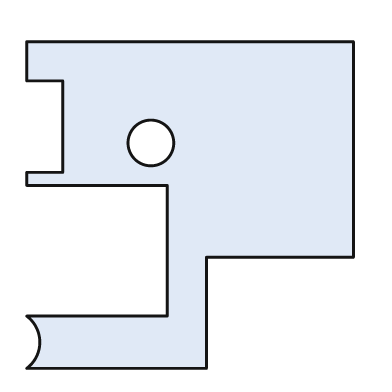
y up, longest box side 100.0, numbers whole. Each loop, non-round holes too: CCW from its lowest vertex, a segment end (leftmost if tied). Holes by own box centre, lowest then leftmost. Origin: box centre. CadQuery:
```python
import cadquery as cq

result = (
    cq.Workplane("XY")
    .moveTo(-50.0, -50.0)
    .lineTo(5.0, -50.0)
    .lineTo(5.0, -16.0)
    .lineTo(50.0, -16.0)
    .lineTo(50.0, 50.0)
    .lineTo(-50.0, 50.0)
    .lineTo(-50.0, 38.0)
    .lineTo(-39.0, 38.0)
    .lineTo(-39.0, 10.0)
    .lineTo(-50.0, 10.0)
    .lineTo(-50.0, 6.0)
    .lineTo(-7.0, 6.0)
    .lineTo(-7.0, -34.0)
    .lineTo(-50.0, -34.0)
    .threePointArc((-46.0, -42.0), (-50.0, -50.0))
    .close()
    .moveTo(-12.0, 19.0)
    .circle(7.0)
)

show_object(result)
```